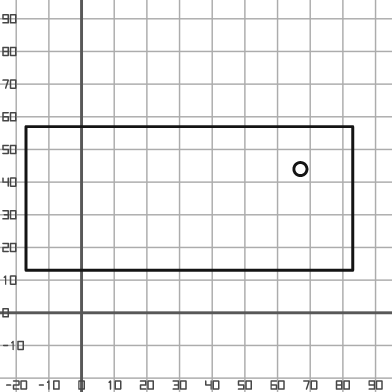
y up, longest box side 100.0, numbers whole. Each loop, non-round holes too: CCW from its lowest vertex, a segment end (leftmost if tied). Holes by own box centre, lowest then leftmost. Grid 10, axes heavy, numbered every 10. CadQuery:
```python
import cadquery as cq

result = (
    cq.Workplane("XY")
    .moveTo(-17.0, 13.0)
    .lineTo(83.0, 13.0)
    .lineTo(83.0, 57.0)
    .lineTo(-17.0, 57.0)
    .close()
    .moveTo(67.0, 44.0)
    .circle(2.0)
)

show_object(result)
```